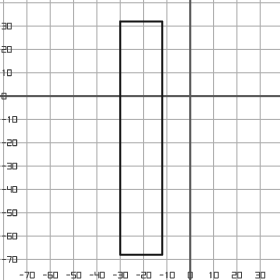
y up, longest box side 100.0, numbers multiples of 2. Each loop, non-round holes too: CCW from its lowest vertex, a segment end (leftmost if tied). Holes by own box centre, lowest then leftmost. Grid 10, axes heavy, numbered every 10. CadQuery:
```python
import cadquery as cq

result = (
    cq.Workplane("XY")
    .moveTo(-30.0, -68.0)
    .lineTo(-12.0, -68.0)
    .lineTo(-12.0, 32.0)
    .lineTo(-30.0, 32.0)
    .close()
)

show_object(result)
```